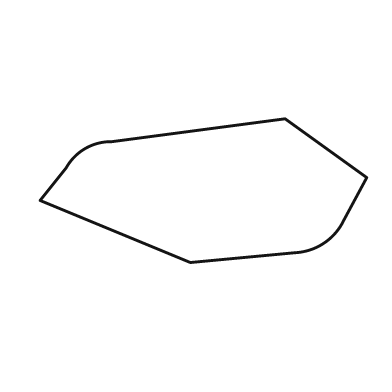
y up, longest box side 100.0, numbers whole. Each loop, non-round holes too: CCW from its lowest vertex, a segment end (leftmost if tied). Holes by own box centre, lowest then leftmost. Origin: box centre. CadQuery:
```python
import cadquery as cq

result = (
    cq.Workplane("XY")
    .moveTo(-4.0, -22.0)
    .lineTo(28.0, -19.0)
    .threePointArc((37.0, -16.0), (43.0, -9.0))
    .lineTo(50.0, 4.0)
    .lineTo(25.0, 22.0)
    .lineTo(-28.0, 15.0)
    .threePointArc((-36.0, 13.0), (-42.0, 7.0))
    .lineTo(-50.0, -3.0)
    .close()
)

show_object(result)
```